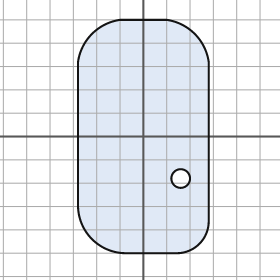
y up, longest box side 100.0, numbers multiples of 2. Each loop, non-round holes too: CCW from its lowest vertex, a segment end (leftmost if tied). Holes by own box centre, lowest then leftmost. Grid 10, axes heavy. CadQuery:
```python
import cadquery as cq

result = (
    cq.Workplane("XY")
    .moveTo(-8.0, -50.0)
    .lineTo(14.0, -50.0)
    .threePointArc((24.0, -46.0), (28.0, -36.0))
    .lineTo(28.0, 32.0)
    .threePointArc((22.0, 44.0), (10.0, 50.0))
    .lineTo(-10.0, 50.0)
    .threePointArc((-22.0, 44.0), (-28.0, 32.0))
    .lineTo(-28.0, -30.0)
    .threePointArc((-22.0, -44.0), (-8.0, -50.0))
    .close()
    .moveTo(16.0, -18.0)
    .circle(4.0)
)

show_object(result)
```